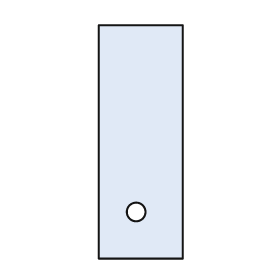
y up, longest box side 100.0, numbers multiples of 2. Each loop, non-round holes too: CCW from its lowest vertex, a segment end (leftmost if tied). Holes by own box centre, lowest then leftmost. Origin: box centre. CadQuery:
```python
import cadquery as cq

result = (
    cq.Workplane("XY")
    .moveTo(-18.0, -50.0)
    .lineTo(18.0, -50.0)
    .lineTo(18.0, 50.0)
    .lineTo(-18.0, 50.0)
    .close()
    .moveTo(-2.0, -30.0)
    .circle(4.0)
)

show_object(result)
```